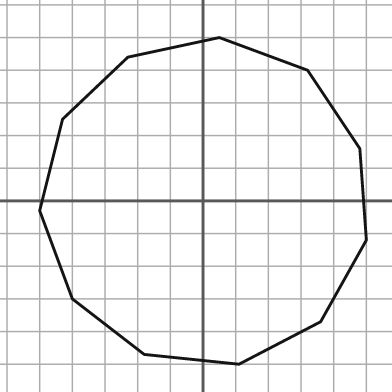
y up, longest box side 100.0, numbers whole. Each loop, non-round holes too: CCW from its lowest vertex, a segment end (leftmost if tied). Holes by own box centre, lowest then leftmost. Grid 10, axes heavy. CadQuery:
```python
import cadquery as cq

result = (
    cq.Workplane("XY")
    .moveTo(11.0, -50.0)
    .lineTo(36.0, -37.0)
    .lineTo(50.0, -12.0)
    .lineTo(48.0, 16.0)
    .lineTo(32.0, 40.0)
    .lineTo(5.0, 50.0)
    .lineTo(-23.0, 44.0)
    .lineTo(-43.0, 25.0)
    .lineTo(-50.0, -3.0)
    .lineTo(-40.0, -30.0)
    .lineTo(-18.0, -47.0)
    .close()
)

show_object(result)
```